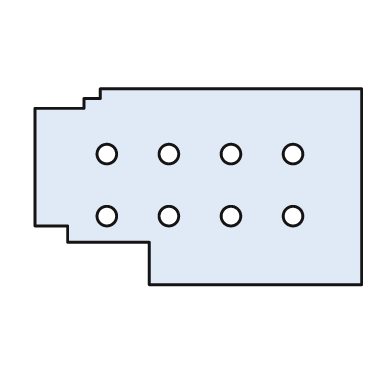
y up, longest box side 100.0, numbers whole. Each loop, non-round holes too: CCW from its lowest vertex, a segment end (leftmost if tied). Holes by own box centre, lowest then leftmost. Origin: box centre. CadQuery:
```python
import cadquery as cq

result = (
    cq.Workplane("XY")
    .moveTo(-15.0, -30.0)
    .lineTo(50.0, -30.0)
    .lineTo(50.0, 30.0)
    .lineTo(-30.0, 30.0)
    .lineTo(-30.0, 27.0)
    .lineTo(-35.0, 27.0)
    .lineTo(-35.0, 24.0)
    .lineTo(-50.0, 24.0)
    .lineTo(-50.0, -12.0)
    .lineTo(-40.0, -12.0)
    .lineTo(-40.0, -17.0)
    .lineTo(-15.0, -17.0)
    .close()
    .moveTo(-28.0, -9.0)
    .circle(3.0)
    .moveTo(-9.0, -9.0)
    .circle(3.0)
    .moveTo(10.0, -9.0)
    .circle(3.0)
    .moveTo(29.0, -9.0)
    .circle(3.0)
    .moveTo(-28.0, 10.0)
    .circle(3.0)
    .moveTo(-9.0, 10.0)
    .circle(3.0)
    .moveTo(10.0, 10.0)
    .circle(3.0)
    .moveTo(29.0, 10.0)
    .circle(3.0)
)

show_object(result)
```